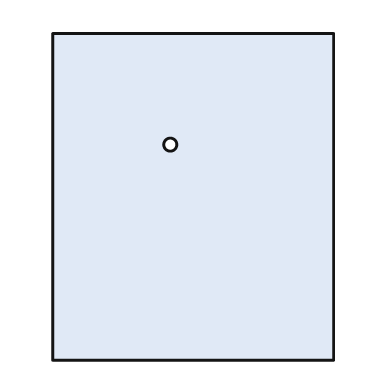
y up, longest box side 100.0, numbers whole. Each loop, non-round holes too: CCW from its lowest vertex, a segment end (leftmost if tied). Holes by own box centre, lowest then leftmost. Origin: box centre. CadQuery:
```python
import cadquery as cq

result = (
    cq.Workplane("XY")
    .moveTo(-43.0, -50.0)
    .lineTo(43.0, -50.0)
    .lineTo(43.0, 50.0)
    .lineTo(-43.0, 50.0)
    .close()
    .moveTo(-7.0, 16.0)
    .circle(2.0)
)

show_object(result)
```